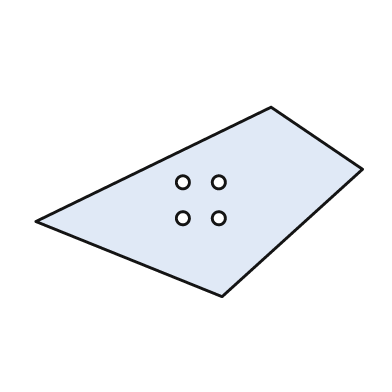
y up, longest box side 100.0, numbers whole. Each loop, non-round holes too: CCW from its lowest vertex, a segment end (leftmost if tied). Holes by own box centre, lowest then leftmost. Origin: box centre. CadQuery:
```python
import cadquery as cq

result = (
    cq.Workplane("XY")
    .moveTo(7.0, -29.0)
    .lineTo(50.0, 10.0)
    .lineTo(22.0, 29.0)
    .lineTo(-50.0, -6.0)
    .close()
    .moveTo(-5.0, -5.0)
    .circle(2.0)
    .moveTo(6.0, -5.0)
    .circle(2.0)
    .moveTo(-5.0, 6.0)
    .circle(2.0)
    .moveTo(6.0, 6.0)
    .circle(2.0)
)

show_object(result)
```